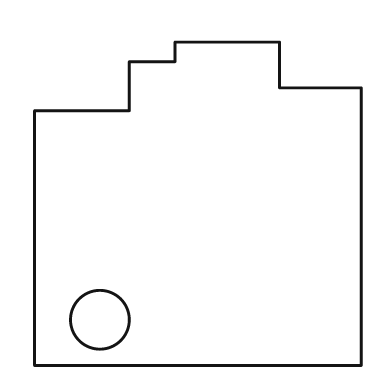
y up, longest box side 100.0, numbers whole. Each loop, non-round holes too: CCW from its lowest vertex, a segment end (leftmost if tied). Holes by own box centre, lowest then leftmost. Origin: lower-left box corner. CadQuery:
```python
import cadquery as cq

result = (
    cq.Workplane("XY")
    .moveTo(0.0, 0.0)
    .lineTo(100.0, 0.0)
    .lineTo(100.0, 85.0)
    .lineTo(75.0, 85.0)
    .lineTo(75.0, 99.0)
    .lineTo(43.0, 99.0)
    .lineTo(43.0, 93.0)
    .lineTo(29.0, 93.0)
    .lineTo(29.0, 78.0)
    .lineTo(0.0, 78.0)
    .close()
    .moveTo(20.0, 14.0)
    .circle(9.0)
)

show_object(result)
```